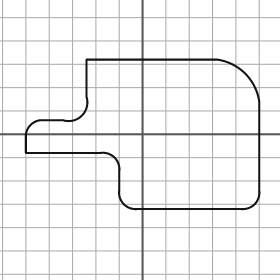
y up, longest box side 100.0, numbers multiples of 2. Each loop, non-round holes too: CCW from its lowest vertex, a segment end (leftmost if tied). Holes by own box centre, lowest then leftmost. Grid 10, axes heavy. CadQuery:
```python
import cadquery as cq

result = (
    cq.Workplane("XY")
    .moveTo(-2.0, -32.0)
    .lineTo(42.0, -32.0)
    .threePointArc((48.0, -30.0), (50.0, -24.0))
    .lineTo(50.0, 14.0)
    .threePointArc((44.0, 26.0), (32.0, 32.0))
    .lineTo(-24.0, 32.0)
    .lineTo(-24.0, 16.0)
    .threePointArc((-26.0, 8.0), (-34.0, 6.0))
    .lineTo(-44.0, 6.0)
    .threePointArc((-48.0, 4.0), (-50.0, 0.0))
    .lineTo(-50.0, -8.0)
    .lineTo(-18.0, -8.0)
    .threePointArc((-12.0, -10.0), (-10.0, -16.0))
    .lineTo(-10.0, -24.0)
    .threePointArc((-8.0, -30.0), (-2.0, -32.0))
    .close()
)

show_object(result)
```